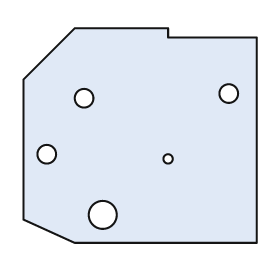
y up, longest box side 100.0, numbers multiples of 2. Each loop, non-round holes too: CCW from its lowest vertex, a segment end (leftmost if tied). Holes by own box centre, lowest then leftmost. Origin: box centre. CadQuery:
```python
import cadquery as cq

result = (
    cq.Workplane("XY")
    .moveTo(-28.0, -46.0)
    .lineTo(50.0, -46.0)
    .lineTo(50.0, 42.0)
    .lineTo(12.0, 42.0)
    .lineTo(12.0, 46.0)
    .lineTo(-28.0, 46.0)
    .lineTo(-50.0, 24.0)
    .lineTo(-50.0, -36.0)
    .close()
    .moveTo(-16.0, -34.0)
    .circle(6.0)
    .moveTo(12.0, -10.0)
    .circle(2.0)
    .moveTo(-40.0, -8.0)
    .circle(4.0)
    .moveTo(-24.0, 16.0)
    .circle(4.0)
    .moveTo(38.0, 18.0)
    .circle(4.0)
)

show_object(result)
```